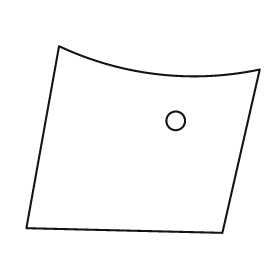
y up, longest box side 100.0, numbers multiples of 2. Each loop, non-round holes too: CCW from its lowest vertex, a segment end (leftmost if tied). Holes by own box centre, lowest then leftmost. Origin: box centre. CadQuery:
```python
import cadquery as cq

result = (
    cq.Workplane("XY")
    .moveTo(34.0, -40.0)
    .lineTo(50.0, 30.0)
    .threePointArc((6.0, 28.0), (-36.0, 40.0))
    .lineTo(-50.0, -38.0)
    .close()
    .moveTo(14.0, 8.0)
    .circle(4.0)
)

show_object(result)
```